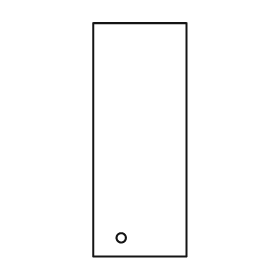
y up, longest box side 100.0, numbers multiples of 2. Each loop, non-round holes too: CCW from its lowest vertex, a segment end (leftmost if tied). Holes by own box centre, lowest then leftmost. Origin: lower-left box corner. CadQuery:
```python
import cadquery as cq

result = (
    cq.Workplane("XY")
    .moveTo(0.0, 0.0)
    .lineTo(40.0, 0.0)
    .lineTo(40.0, 100.0)
    .lineTo(0.0, 100.0)
    .close()
    .moveTo(12.0, 8.0)
    .circle(2.0)
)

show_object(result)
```